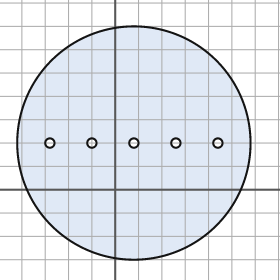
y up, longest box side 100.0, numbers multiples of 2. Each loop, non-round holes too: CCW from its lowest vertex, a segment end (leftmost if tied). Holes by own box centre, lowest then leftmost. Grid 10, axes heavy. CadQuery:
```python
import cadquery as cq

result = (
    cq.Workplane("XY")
    .moveTo(8.0, 20.0)
    .circle(50.0)
    .moveTo(-28.0, 20.0)
    .circle(2.0)
    .moveTo(-10.0, 20.0)
    .circle(2.0)
    .moveTo(8.0, 20.0)
    .circle(2.0)
    .moveTo(26.0, 20.0)
    .circle(2.0)
    .moveTo(44.0, 20.0)
    .circle(2.0)
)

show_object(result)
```